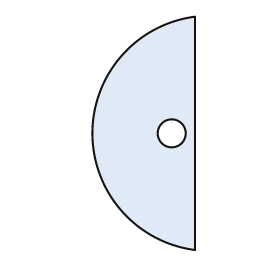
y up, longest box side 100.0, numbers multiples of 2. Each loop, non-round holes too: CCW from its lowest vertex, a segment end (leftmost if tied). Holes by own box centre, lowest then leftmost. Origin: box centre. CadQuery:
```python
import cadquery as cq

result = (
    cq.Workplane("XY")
    .moveTo(22.0, -50.0)
    .lineTo(22.0, 50.0)
    .threePointArc((-22.0, 0.0), (22.0, -50.0))
    .close()
    .moveTo(12.0, 0.0)
    .circle(6.0)
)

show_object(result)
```